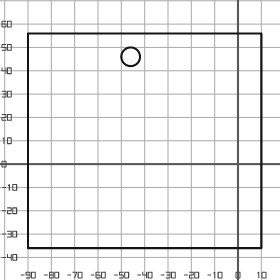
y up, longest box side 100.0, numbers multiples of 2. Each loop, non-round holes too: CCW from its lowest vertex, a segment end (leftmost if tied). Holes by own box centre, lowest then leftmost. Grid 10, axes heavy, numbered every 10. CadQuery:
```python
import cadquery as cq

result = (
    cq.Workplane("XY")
    .moveTo(-90.0, -36.0)
    .lineTo(10.0, -36.0)
    .lineTo(10.0, 56.0)
    .lineTo(-90.0, 56.0)
    .close()
    .moveTo(-46.0, 46.0)
    .circle(4.0)
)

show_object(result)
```